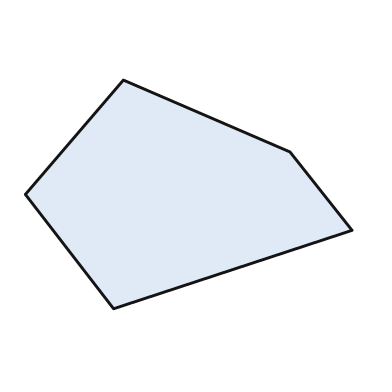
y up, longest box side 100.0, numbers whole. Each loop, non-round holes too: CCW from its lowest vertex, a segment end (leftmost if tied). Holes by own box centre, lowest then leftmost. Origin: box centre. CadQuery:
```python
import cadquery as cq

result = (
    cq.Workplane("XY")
    .moveTo(-23.0, -35.0)
    .lineTo(50.0, -11.0)
    .lineTo(31.0, 13.0)
    .lineTo(-20.0, 35.0)
    .lineTo(-50.0, 0.0)
    .close()
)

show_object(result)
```